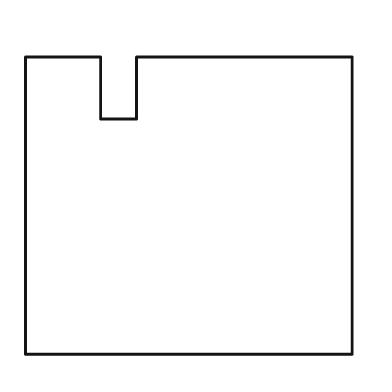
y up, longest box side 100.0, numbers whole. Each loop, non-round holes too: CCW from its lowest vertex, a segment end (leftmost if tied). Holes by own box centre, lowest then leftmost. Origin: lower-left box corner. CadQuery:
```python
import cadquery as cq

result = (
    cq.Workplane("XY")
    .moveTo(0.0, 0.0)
    .lineTo(100.0, 0.0)
    .lineTo(100.0, 91.0)
    .lineTo(34.0, 91.0)
    .lineTo(34.0, 72.0)
    .lineTo(23.0, 72.0)
    .lineTo(23.0, 91.0)
    .lineTo(0.0, 91.0)
    .close()
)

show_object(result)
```